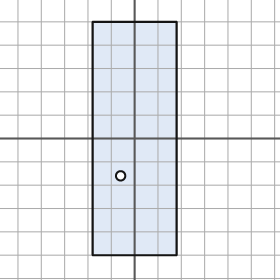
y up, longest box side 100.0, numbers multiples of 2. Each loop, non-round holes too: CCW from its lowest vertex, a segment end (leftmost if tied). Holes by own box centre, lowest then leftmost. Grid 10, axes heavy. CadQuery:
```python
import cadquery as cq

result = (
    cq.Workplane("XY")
    .moveTo(-18.0, -50.0)
    .lineTo(18.0, -50.0)
    .lineTo(18.0, 50.0)
    .lineTo(-18.0, 50.0)
    .close()
    .moveTo(-6.0, -16.0)
    .circle(2.0)
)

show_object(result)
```